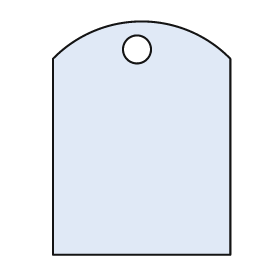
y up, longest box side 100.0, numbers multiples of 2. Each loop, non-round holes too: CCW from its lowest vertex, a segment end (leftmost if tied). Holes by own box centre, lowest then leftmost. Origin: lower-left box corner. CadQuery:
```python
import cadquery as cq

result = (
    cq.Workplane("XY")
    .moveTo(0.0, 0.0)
    .lineTo(76.0, 0.0)
    .lineTo(76.0, 84.0)
    .threePointArc((38.0, 100.0), (0.0, 84.0))
    .close()
    .moveTo(36.0, 88.0)
    .circle(6.0)
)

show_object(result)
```